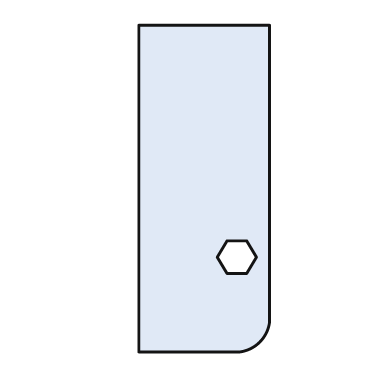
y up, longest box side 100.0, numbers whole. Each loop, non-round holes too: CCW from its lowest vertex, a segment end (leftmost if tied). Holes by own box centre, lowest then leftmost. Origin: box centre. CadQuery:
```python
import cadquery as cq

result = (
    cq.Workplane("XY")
    .moveTo(-20.0, -50.0)
    .lineTo(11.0, -50.0)
    .threePointArc((17.0, -47.0), (20.0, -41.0))
    .lineTo(20.0, 50.0)
    .lineTo(-20.0, 50.0)
    .close()
    .moveTo(7.0, -26.0)
    .lineTo(13.0, -26.0)
    .lineTo(16.0, -21.0)
    .lineTo(13.0, -16.0)
    .lineTo(7.0, -16.0)
    .lineTo(4.0, -21.0)
    .close()
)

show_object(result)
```